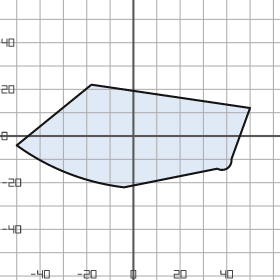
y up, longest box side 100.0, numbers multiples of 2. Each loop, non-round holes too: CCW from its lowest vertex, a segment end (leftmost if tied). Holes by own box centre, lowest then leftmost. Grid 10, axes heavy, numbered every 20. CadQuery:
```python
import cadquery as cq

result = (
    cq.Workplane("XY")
    .moveTo(-4.0, -22.0)
    .lineTo(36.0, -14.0)
    .threePointArc((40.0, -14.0), (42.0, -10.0))
    .lineTo(50.0, 12.0)
    .lineTo(-18.0, 22.0)
    .lineTo(-50.0, -4.0)
    .threePointArc((-28.0, -16.0), (-4.0, -22.0))
    .close()
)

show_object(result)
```